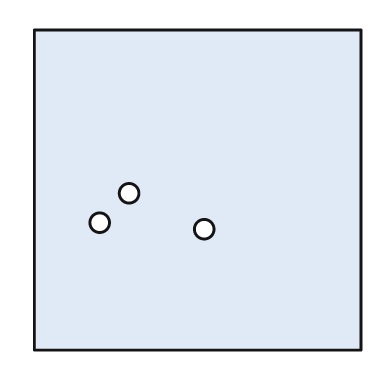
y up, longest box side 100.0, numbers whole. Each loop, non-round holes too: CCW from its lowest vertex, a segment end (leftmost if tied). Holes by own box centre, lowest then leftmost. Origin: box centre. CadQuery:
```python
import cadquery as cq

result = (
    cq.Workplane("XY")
    .moveTo(-50.0, -49.0)
    .lineTo(50.0, -49.0)
    .lineTo(50.0, 49.0)
    .lineTo(-50.0, 49.0)
    .close()
    .moveTo(2.0, -12.0)
    .circle(3.0)
    .moveTo(-30.0, -10.0)
    .circle(3.0)
    .moveTo(-21.0, -1.0)
    .circle(3.0)
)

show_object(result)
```